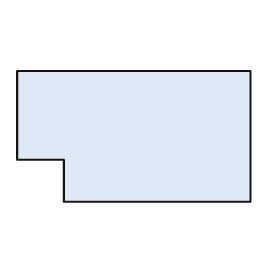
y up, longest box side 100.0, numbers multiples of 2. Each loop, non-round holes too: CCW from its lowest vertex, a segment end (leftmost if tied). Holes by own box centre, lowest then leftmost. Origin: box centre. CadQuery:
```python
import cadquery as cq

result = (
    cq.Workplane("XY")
    .moveTo(-30.0, -28.0)
    .lineTo(50.0, -28.0)
    .lineTo(50.0, 28.0)
    .lineTo(-50.0, 28.0)
    .lineTo(-50.0, -10.0)
    .lineTo(-30.0, -10.0)
    .close()
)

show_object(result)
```